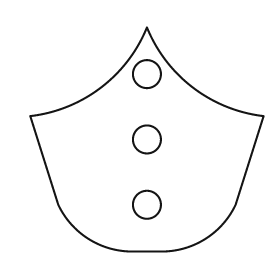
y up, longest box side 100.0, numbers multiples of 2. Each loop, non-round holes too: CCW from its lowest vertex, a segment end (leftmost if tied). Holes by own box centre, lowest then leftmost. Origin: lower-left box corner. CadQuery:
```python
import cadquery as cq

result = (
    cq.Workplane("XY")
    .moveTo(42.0, 0.0)
    .lineTo(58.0, 0.0)
    .threePointArc((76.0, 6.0), (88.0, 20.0))
    .lineTo(100.0, 58.0)
    .threePointArc((70.0, 70.0), (50.0, 96.0))
    .threePointArc((30.0, 70.0), (0.0, 58.0))
    .lineTo(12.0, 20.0)
    .threePointArc((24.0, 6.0), (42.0, 0.0))
    .close()
    .moveTo(50.0, 20.0)
    .circle(6.0)
    .moveTo(50.0, 48.0)
    .circle(6.0)
    .moveTo(50.0, 76.0)
    .circle(6.0)
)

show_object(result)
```